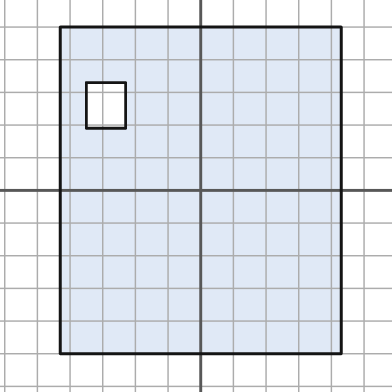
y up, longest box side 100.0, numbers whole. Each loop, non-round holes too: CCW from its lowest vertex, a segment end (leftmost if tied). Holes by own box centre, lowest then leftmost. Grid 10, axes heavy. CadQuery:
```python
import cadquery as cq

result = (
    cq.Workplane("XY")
    .moveTo(-43.0, -50.0)
    .lineTo(43.0, -50.0)
    .lineTo(43.0, 50.0)
    .lineTo(-43.0, 50.0)
    .close()
    .moveTo(-35.0, 19.0)
    .lineTo(-23.0, 19.0)
    .lineTo(-23.0, 33.0)
    .lineTo(-35.0, 33.0)
    .close()
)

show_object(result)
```